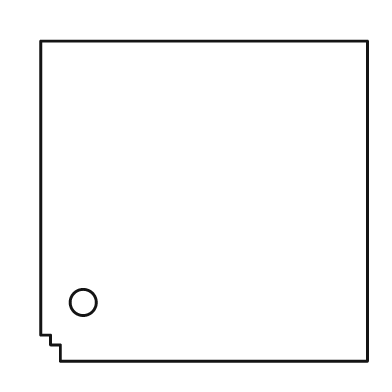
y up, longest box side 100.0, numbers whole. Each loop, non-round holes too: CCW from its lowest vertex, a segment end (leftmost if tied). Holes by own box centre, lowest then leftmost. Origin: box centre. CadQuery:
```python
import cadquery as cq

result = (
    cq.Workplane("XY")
    .moveTo(-44.0, -49.0)
    .lineTo(50.0, -49.0)
    .lineTo(50.0, 49.0)
    .lineTo(-50.0, 49.0)
    .lineTo(-50.0, -41.0)
    .lineTo(-47.0, -41.0)
    .lineTo(-47.0, -44.0)
    .lineTo(-44.0, -44.0)
    .close()
    .moveTo(-37.0, -31.0)
    .circle(4.0)
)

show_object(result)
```